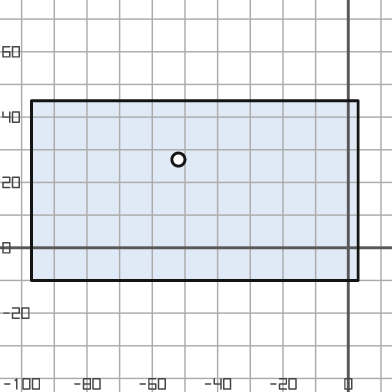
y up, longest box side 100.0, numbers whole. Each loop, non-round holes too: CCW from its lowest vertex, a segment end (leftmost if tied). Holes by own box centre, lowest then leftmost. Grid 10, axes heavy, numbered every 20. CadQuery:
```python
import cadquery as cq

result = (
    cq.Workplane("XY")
    .moveTo(-97.0, -10.0)
    .lineTo(3.0, -10.0)
    .lineTo(3.0, 45.0)
    .lineTo(-97.0, 45.0)
    .close()
    .moveTo(-52.0, 27.0)
    .circle(2.0)
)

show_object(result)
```